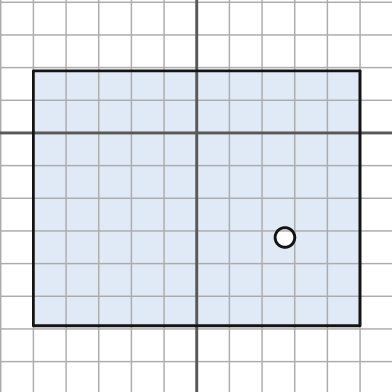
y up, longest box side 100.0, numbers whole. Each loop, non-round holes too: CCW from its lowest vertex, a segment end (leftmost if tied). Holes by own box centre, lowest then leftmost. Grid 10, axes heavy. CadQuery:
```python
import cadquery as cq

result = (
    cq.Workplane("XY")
    .moveTo(-50.0, -59.0)
    .lineTo(50.0, -59.0)
    .lineTo(50.0, 19.0)
    .lineTo(-50.0, 19.0)
    .close()
    .moveTo(27.0, -32.0)
    .circle(3.0)
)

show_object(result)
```